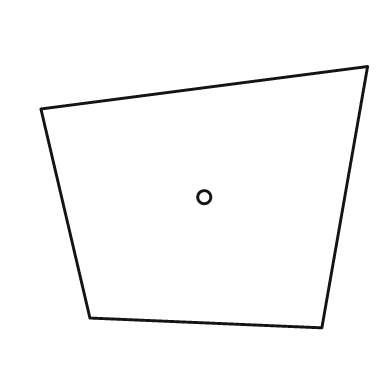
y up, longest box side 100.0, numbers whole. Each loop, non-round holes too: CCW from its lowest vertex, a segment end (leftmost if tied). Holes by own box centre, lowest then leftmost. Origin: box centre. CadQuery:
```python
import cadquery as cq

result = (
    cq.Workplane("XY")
    .moveTo(36.0, -40.0)
    .lineTo(50.0, 40.0)
    .lineTo(-50.0, 27.0)
    .lineTo(-35.0, -37.0)
    .close()
    .moveTo(0.0, 0.0)
    .circle(2.0)
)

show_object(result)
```